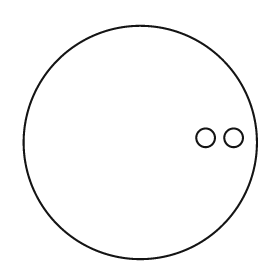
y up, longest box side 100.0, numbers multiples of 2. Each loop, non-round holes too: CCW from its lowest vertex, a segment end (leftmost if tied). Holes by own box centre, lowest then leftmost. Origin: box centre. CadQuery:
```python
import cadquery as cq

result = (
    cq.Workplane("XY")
    .moveTo(0.0, 0.0)
    .circle(50.0)
    .moveTo(28.0, 2.0)
    .circle(4.0)
    .moveTo(40.0, 2.0)
    .circle(4.0)
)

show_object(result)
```